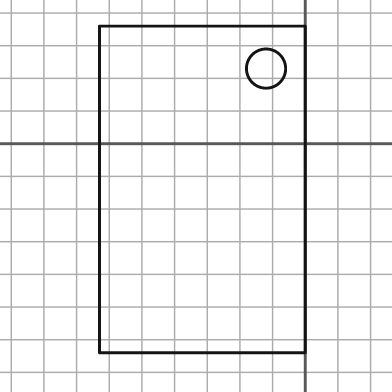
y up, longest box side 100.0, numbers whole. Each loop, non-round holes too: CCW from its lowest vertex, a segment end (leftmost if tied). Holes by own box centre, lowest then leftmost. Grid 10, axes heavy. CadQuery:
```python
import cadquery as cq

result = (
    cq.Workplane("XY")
    .moveTo(-63.0, -64.0)
    .lineTo(0.0, -64.0)
    .lineTo(0.0, 36.0)
    .lineTo(-63.0, 36.0)
    .close()
    .moveTo(-12.0, 23.0)
    .circle(6.0)
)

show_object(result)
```